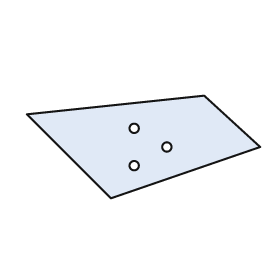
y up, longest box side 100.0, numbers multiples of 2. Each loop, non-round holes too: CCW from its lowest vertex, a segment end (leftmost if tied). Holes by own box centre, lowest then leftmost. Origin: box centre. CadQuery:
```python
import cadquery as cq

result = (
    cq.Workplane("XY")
    .moveTo(-14.0, -22.0)
    .lineTo(50.0, 0.0)
    .lineTo(26.0, 22.0)
    .lineTo(-50.0, 14.0)
    .close()
    .moveTo(-4.0, -8.0)
    .circle(2.0)
    .moveTo(10.0, 0.0)
    .circle(2.0)
    .moveTo(-4.0, 8.0)
    .circle(2.0)
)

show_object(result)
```